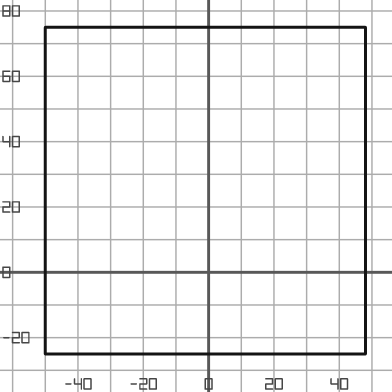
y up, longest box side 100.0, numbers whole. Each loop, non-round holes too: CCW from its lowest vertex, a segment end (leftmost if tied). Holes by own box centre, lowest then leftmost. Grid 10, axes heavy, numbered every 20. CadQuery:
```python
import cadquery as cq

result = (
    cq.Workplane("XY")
    .moveTo(-50.0, -25.0)
    .lineTo(48.0, -25.0)
    .lineTo(48.0, 75.0)
    .lineTo(-50.0, 75.0)
    .close()
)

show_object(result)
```